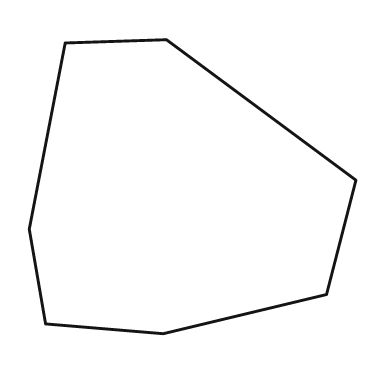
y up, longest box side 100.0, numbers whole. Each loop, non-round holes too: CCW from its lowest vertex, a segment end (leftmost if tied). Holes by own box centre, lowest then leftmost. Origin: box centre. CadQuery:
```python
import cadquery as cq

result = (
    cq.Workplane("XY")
    .moveTo(-9.0, -45.0)
    .lineTo(41.0, -33.0)
    .lineTo(50.0, 2.0)
    .lineTo(-8.0, 45.0)
    .lineTo(-39.0, 44.0)
    .lineTo(-50.0, -13.0)
    .lineTo(-45.0, -42.0)
    .close()
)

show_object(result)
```